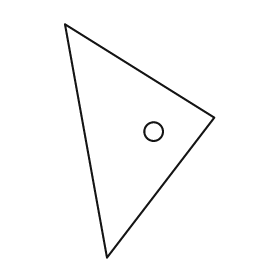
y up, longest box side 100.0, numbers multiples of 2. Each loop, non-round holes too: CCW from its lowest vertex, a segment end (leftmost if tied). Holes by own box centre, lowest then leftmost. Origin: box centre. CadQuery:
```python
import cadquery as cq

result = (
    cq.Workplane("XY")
    .moveTo(-14.0, -50.0)
    .lineTo(32.0, 10.0)
    .lineTo(-32.0, 50.0)
    .close()
    .moveTo(6.0, 4.0)
    .circle(4.0)
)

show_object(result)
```